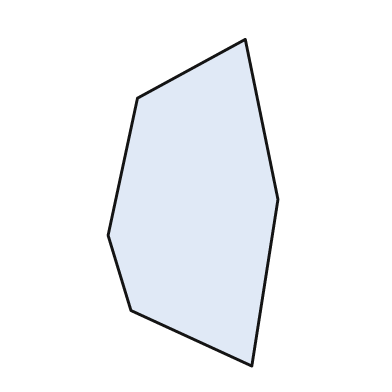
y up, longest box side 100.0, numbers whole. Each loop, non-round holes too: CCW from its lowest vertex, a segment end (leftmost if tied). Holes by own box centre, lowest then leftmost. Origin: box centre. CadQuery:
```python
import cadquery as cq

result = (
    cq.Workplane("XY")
    .moveTo(18.0, -50.0)
    .lineTo(26.0, 1.0)
    .lineTo(16.0, 50.0)
    .lineTo(-17.0, 32.0)
    .lineTo(-26.0, -10.0)
    .lineTo(-19.0, -33.0)
    .close()
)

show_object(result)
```